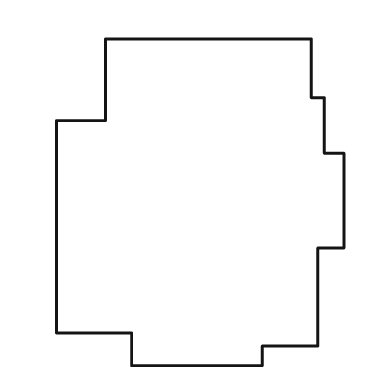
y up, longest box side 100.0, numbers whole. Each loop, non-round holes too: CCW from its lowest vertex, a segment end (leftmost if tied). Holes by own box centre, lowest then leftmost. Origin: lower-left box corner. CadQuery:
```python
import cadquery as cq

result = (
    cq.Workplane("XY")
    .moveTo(23.0, 0.0)
    .lineTo(63.0, 0.0)
    .lineTo(63.0, 6.0)
    .lineTo(80.0, 6.0)
    .lineTo(80.0, 36.0)
    .lineTo(88.0, 36.0)
    .lineTo(88.0, 65.0)
    .lineTo(82.0, 65.0)
    .lineTo(82.0, 82.0)
    .lineTo(78.0, 82.0)
    .lineTo(78.0, 100.0)
    .lineTo(15.0, 100.0)
    .lineTo(15.0, 75.0)
    .lineTo(0.0, 75.0)
    .lineTo(0.0, 10.0)
    .lineTo(23.0, 10.0)
    .close()
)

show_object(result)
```